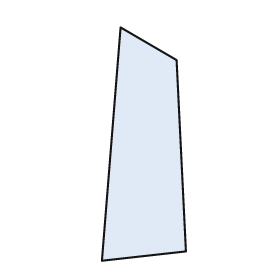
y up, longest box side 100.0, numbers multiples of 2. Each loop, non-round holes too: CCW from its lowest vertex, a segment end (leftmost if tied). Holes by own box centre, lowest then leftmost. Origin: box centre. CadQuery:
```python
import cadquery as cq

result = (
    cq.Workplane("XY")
    .moveTo(-18.0, -50.0)
    .lineTo(18.0, -46.0)
    .lineTo(14.0, 36.0)
    .lineTo(-10.0, 50.0)
    .close()
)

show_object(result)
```